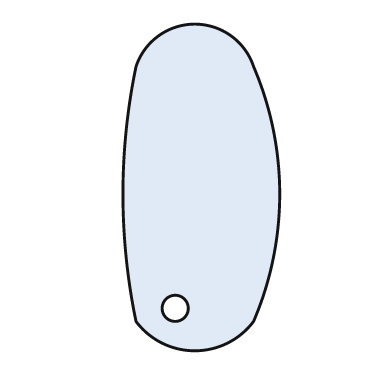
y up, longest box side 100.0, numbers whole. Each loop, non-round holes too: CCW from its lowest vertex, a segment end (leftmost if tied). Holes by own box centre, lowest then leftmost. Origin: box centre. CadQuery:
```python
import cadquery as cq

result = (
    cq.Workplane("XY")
    .moveTo(-20.0, -41.0)
    .threePointArc((-2.0, -50.0), (16.0, -41.0))
    .threePointArc((24.0, -2.0), (16.0, 37.0))
    .threePointArc((-2.0, 50.0), (-20.0, 37.0))
    .threePointArc((-24.0, -2.0), (-20.0, -41.0))
    .close()
    .moveTo(-8.0, -37.0)
    .circle(4.0)
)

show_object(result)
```